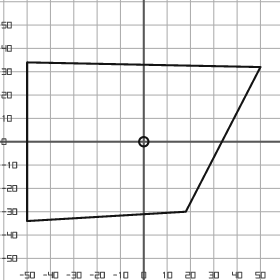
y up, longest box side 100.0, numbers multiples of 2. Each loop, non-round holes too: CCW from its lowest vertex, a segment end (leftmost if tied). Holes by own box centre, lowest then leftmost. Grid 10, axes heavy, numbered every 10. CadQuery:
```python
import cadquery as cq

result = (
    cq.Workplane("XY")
    .moveTo(-50.0, -34.0)
    .lineTo(18.0, -30.0)
    .lineTo(50.0, 32.0)
    .lineTo(-50.0, 34.0)
    .close()
    .moveTo(0.0, 0.0)
    .circle(2.0)
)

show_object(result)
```